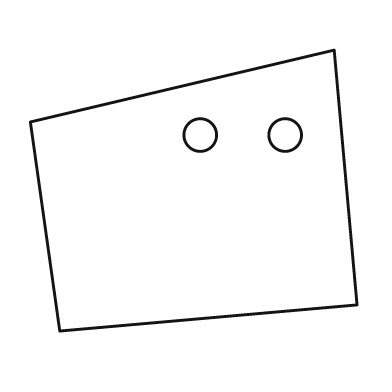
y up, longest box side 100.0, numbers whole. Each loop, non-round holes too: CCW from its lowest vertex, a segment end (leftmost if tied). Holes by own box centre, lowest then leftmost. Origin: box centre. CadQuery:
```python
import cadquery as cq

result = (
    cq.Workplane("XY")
    .moveTo(-41.0, -43.0)
    .lineTo(50.0, -35.0)
    .lineTo(43.0, 43.0)
    .lineTo(-50.0, 21.0)
    .close()
    .moveTo(2.0, 17.0)
    .circle(5.0)
    .moveTo(28.0, 17.0)
    .circle(5.0)
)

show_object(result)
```